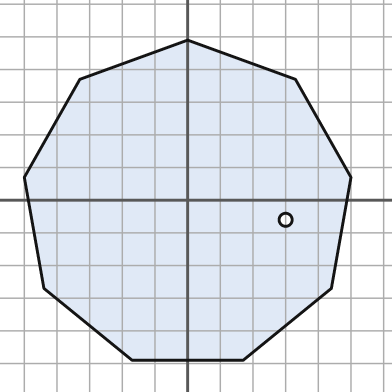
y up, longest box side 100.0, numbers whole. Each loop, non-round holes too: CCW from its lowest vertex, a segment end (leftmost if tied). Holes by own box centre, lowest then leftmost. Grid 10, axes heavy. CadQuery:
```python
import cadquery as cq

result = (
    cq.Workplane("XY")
    .moveTo(-17.0, -49.0)
    .lineTo(17.0, -49.0)
    .lineTo(44.0, -27.0)
    .lineTo(50.0, 7.0)
    .lineTo(33.0, 37.0)
    .lineTo(0.0, 49.0)
    .lineTo(-33.0, 37.0)
    .lineTo(-50.0, 7.0)
    .lineTo(-44.0, -27.0)
    .close()
    .moveTo(30.0, -6.0)
    .circle(2.0)
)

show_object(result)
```